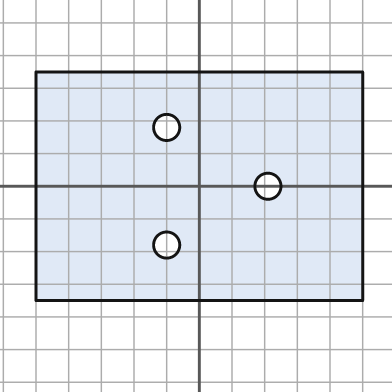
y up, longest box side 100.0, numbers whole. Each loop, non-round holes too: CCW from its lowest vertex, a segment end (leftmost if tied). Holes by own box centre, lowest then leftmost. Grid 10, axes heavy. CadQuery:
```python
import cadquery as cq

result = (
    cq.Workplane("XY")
    .moveTo(-50.0, -35.0)
    .lineTo(50.0, -35.0)
    .lineTo(50.0, 35.0)
    .lineTo(-50.0, 35.0)
    .close()
    .moveTo(-10.0, -18.0)
    .circle(4.0)
    .moveTo(21.0, 0.0)
    .circle(4.0)
    .moveTo(-10.0, 18.0)
    .circle(4.0)
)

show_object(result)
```